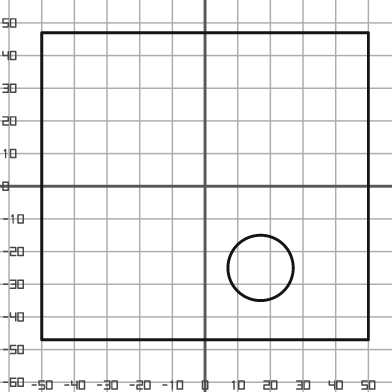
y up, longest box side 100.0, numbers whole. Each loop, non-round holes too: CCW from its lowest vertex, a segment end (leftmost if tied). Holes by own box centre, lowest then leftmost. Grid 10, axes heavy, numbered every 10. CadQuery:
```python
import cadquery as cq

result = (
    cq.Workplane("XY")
    .moveTo(-50.0, -47.0)
    .lineTo(50.0, -47.0)
    .lineTo(50.0, 47.0)
    .lineTo(-50.0, 47.0)
    .close()
    .moveTo(17.0, -25.0)
    .circle(10.0)
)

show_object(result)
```